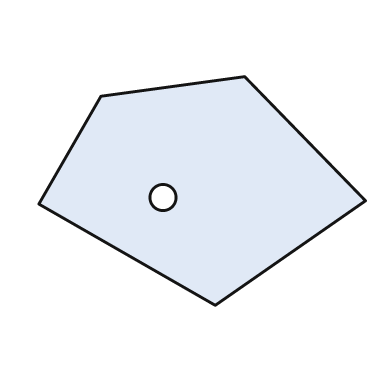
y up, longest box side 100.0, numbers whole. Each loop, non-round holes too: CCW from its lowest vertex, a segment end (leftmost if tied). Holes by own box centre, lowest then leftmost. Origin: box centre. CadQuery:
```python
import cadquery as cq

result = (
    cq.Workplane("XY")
    .moveTo(4.0, -35.0)
    .lineTo(50.0, -3.0)
    .lineTo(13.0, 35.0)
    .lineTo(-31.0, 29.0)
    .lineTo(-50.0, -4.0)
    .close()
    .moveTo(-12.0, -2.0)
    .circle(4.0)
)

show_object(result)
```